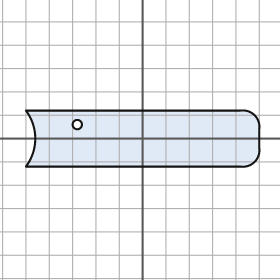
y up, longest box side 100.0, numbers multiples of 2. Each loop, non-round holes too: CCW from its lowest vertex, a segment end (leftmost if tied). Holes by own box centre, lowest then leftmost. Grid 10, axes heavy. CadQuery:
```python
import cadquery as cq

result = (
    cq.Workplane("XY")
    .moveTo(-50.0, -12.0)
    .lineTo(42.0, -12.0)
    .threePointArc((48.0, -10.0), (50.0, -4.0))
    .lineTo(50.0, 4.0)
    .threePointArc((48.0, 10.0), (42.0, 12.0))
    .lineTo(-50.0, 12.0)
    .threePointArc((-46.0, 0.0), (-50.0, -12.0))
    .close()
    .moveTo(-28.0, 6.0)
    .circle(2.0)
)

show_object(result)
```